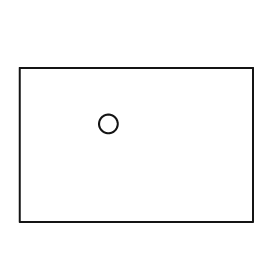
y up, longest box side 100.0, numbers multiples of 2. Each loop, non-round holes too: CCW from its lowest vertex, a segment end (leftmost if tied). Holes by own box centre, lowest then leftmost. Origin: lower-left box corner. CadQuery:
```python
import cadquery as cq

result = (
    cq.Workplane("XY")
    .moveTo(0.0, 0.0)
    .lineTo(100.0, 0.0)
    .lineTo(100.0, 66.0)
    .lineTo(0.0, 66.0)
    .close()
    .moveTo(38.0, 42.0)
    .circle(4.0)
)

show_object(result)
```